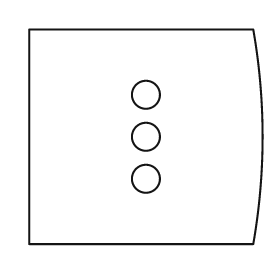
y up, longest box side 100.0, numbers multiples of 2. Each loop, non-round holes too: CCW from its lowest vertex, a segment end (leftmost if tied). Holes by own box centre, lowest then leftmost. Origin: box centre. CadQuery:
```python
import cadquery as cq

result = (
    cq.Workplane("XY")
    .moveTo(-50.0, -46.0)
    .lineTo(46.0, -46.0)
    .threePointArc((50.0, 0.0), (46.0, 46.0))
    .lineTo(-50.0, 46.0)
    .close()
    .moveTo(0.0, -18.0)
    .circle(6.0)
    .moveTo(0.0, 0.0)
    .circle(6.0)
    .moveTo(0.0, 18.0)
    .circle(6.0)
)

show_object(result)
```